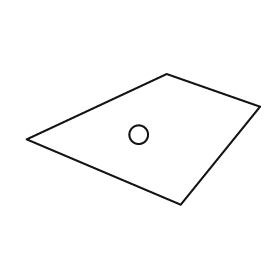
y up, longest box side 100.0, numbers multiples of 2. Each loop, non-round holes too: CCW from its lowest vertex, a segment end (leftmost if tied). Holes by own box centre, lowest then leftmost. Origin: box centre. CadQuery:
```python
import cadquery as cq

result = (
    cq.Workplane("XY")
    .moveTo(16.0, -28.0)
    .lineTo(50.0, 14.0)
    .lineTo(10.0, 28.0)
    .lineTo(-50.0, 0.0)
    .close()
    .moveTo(-2.0, 2.0)
    .circle(4.0)
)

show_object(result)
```